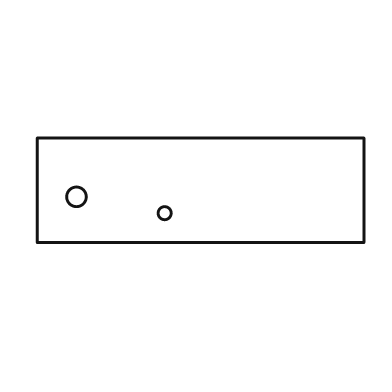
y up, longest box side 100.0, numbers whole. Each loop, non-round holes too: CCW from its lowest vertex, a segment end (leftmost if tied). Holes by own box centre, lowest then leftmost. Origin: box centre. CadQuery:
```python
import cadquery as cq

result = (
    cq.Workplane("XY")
    .moveTo(-50.0, -16.0)
    .lineTo(50.0, -16.0)
    .lineTo(50.0, 16.0)
    .lineTo(-50.0, 16.0)
    .close()
    .moveTo(-11.0, -7.0)
    .circle(2.0)
    .moveTo(-38.0, -2.0)
    .circle(3.0)
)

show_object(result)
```